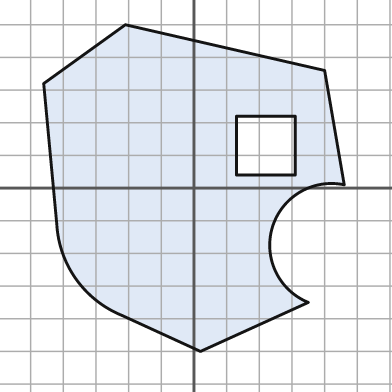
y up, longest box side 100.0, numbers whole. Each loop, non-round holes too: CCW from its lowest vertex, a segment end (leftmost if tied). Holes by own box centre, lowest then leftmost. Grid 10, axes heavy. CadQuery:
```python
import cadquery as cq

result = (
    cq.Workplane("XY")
    .moveTo(2.0, -50.0)
    .lineTo(35.0, -35.0)
    .threePointArc((24.0, -12.0), (46.0, 1.0))
    .lineTo(40.0, 36.0)
    .lineTo(-21.0, 50.0)
    .lineTo(-46.0, 32.0)
    .lineTo(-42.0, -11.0)
    .threePointArc((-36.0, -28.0), (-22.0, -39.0))
    .close()
    .moveTo(13.0, 4.0)
    .lineTo(31.0, 4.0)
    .lineTo(31.0, 22.0)
    .lineTo(13.0, 22.0)
    .close()
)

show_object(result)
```